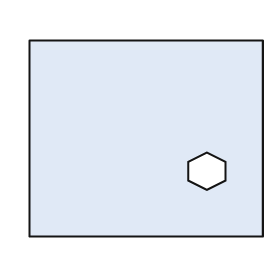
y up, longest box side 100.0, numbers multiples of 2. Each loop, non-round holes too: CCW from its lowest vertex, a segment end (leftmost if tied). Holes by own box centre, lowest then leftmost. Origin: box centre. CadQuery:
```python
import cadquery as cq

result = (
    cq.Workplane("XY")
    .moveTo(-50.0, -42.0)
    .lineTo(50.0, -42.0)
    .lineTo(50.0, 42.0)
    .lineTo(-50.0, 42.0)
    .close()
    .moveTo(26.0, -22.0)
    .lineTo(34.0, -18.0)
    .lineTo(34.0, -10.0)
    .lineTo(26.0, -6.0)
    .lineTo(18.0, -10.0)
    .lineTo(18.0, -18.0)
    .close()
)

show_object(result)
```